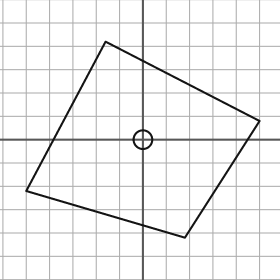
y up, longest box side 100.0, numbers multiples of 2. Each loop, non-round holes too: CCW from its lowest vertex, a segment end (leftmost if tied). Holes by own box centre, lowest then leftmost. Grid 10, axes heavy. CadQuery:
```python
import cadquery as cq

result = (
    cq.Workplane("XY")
    .moveTo(18.0, -42.0)
    .lineTo(50.0, 8.0)
    .lineTo(-16.0, 42.0)
    .lineTo(-50.0, -22.0)
    .close()
    .moveTo(0.0, 0.0)
    .circle(4.0)
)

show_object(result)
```